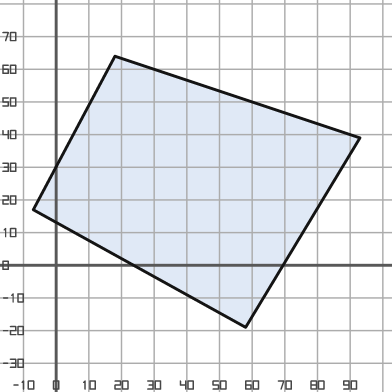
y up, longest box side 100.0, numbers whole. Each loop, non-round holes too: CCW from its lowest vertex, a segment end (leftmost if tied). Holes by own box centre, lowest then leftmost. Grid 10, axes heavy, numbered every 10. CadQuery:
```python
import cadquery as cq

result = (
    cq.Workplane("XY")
    .moveTo(58.0, -19.0)
    .lineTo(93.0, 39.0)
    .lineTo(18.0, 64.0)
    .lineTo(-7.0, 17.0)
    .close()
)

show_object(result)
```